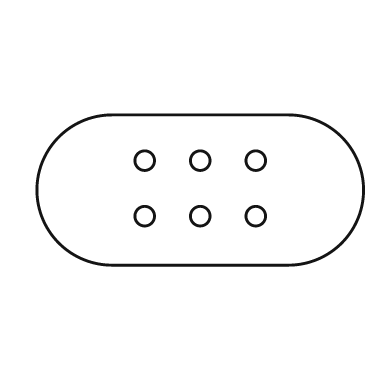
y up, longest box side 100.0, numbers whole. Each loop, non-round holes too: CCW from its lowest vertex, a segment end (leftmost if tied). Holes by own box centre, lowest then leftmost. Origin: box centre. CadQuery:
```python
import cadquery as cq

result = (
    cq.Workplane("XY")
    .moveTo(-27.0, -23.0)
    .lineTo(27.0, -23.0)
    .threePointArc((50.0, 0.0), (27.0, 23.0))
    .lineTo(-27.0, 23.0)
    .threePointArc((-50.0, 0.0), (-27.0, -23.0))
    .close()
    .moveTo(-17.0, -8.0)
    .circle(3.0)
    .moveTo(0.0, -8.0)
    .circle(3.0)
    .moveTo(17.0, -8.0)
    .circle(3.0)
    .moveTo(-17.0, 9.0)
    .circle(3.0)
    .moveTo(0.0, 9.0)
    .circle(3.0)
    .moveTo(17.0, 9.0)
    .circle(3.0)
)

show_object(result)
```